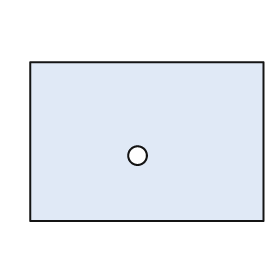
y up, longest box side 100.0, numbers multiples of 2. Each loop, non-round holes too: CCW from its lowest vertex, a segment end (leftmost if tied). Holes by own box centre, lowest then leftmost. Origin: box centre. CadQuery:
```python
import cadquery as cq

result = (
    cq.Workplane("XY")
    .moveTo(-50.0, -34.0)
    .lineTo(50.0, -34.0)
    .lineTo(50.0, 34.0)
    .lineTo(-50.0, 34.0)
    .close()
    .moveTo(-4.0, -6.0)
    .circle(4.0)
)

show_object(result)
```